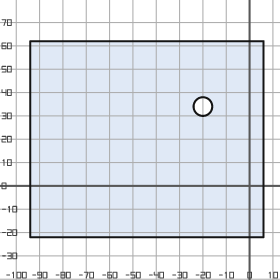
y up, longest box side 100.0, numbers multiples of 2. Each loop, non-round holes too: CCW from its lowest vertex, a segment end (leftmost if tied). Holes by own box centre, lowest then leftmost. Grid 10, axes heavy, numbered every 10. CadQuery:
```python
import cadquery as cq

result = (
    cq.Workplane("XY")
    .moveTo(-94.0, -22.0)
    .lineTo(6.0, -22.0)
    .lineTo(6.0, 62.0)
    .lineTo(-94.0, 62.0)
    .close()
    .moveTo(-20.0, 34.0)
    .circle(4.0)
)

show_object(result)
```